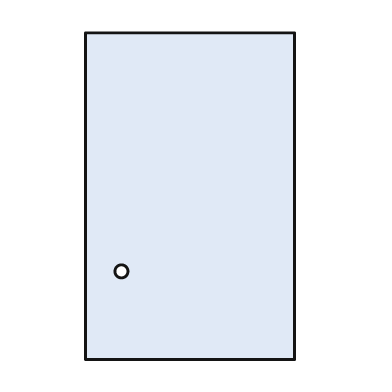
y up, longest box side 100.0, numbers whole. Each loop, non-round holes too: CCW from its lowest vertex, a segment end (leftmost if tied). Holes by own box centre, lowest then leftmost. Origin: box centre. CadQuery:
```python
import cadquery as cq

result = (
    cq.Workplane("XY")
    .moveTo(-32.0, -50.0)
    .lineTo(32.0, -50.0)
    .lineTo(32.0, 50.0)
    .lineTo(-32.0, 50.0)
    .close()
    .moveTo(-21.0, -23.0)
    .circle(2.0)
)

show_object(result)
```